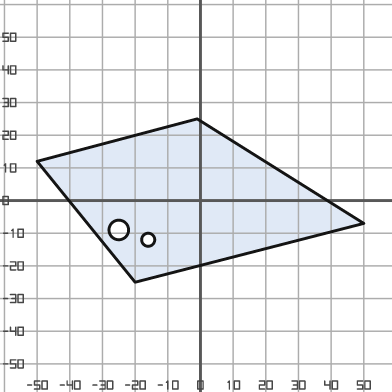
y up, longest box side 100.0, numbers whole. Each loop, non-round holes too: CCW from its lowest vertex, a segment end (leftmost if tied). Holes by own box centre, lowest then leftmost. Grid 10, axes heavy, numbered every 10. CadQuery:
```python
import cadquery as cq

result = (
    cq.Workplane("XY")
    .moveTo(-20.0, -25.0)
    .lineTo(50.0, -7.0)
    .lineTo(-1.0, 25.0)
    .lineTo(-50.0, 12.0)
    .close()
    .moveTo(-16.0, -12.0)
    .circle(2.0)
    .moveTo(-25.0, -9.0)
    .circle(3.0)
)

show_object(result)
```